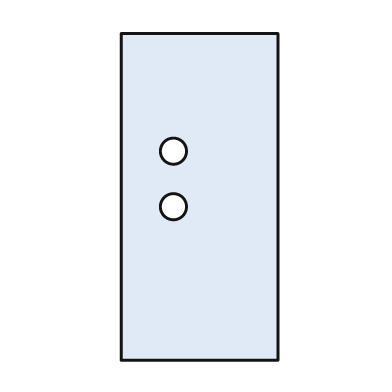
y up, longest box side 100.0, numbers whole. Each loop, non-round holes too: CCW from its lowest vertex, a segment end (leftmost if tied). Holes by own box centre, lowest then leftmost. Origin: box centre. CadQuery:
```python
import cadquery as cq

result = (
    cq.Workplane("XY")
    .moveTo(-24.0, -50.0)
    .lineTo(24.0, -50.0)
    .lineTo(24.0, 50.0)
    .lineTo(-24.0, 50.0)
    .close()
    .moveTo(-8.0, -3.0)
    .circle(4.0)
    .moveTo(-8.0, 14.0)
    .circle(4.0)
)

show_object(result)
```